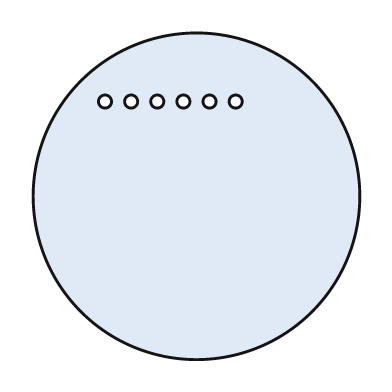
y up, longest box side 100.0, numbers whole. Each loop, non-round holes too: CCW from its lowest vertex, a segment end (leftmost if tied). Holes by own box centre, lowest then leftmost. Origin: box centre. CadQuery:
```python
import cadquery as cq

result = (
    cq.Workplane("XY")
    .moveTo(0.0, 0.0)
    .circle(50.0)
    .moveTo(-28.0, 29.0)
    .circle(2.0)
    .moveTo(-20.0, 29.0)
    .circle(2.0)
    .moveTo(-12.0, 29.0)
    .circle(2.0)
    .moveTo(-4.0, 29.0)
    .circle(2.0)
    .moveTo(4.0, 29.0)
    .circle(2.0)
    .moveTo(12.0, 29.0)
    .circle(2.0)
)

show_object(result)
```